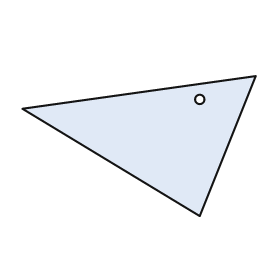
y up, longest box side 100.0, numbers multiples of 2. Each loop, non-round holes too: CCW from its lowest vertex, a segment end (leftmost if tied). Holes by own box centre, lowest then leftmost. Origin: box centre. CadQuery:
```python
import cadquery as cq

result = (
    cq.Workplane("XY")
    .moveTo(26.0, -30.0)
    .lineTo(50.0, 30.0)
    .lineTo(-50.0, 16.0)
    .close()
    .moveTo(26.0, 20.0)
    .circle(2.0)
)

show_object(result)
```